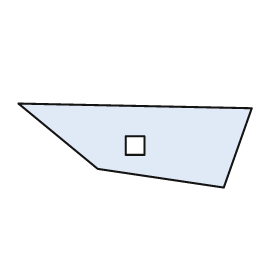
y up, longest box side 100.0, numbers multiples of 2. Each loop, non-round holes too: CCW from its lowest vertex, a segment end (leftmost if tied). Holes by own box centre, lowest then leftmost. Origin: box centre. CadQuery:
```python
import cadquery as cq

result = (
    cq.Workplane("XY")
    .moveTo(38.0, -18.0)
    .lineTo(50.0, 16.0)
    .lineTo(-50.0, 18.0)
    .lineTo(-16.0, -10.0)
    .close()
    .moveTo(-4.0, -4.0)
    .lineTo(4.0, -4.0)
    .lineTo(4.0, 4.0)
    .lineTo(-4.0, 4.0)
    .close()
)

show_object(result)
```